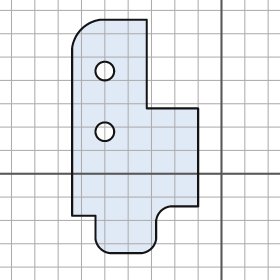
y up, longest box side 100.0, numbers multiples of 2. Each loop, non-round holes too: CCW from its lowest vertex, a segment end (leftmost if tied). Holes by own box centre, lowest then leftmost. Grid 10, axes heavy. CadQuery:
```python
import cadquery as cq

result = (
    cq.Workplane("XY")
    .moveTo(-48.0, -34.0)
    .lineTo(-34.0, -34.0)
    .threePointArc((-30.0, -32.0), (-28.0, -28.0))
    .lineTo(-28.0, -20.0)
    .threePointArc((-26.0, -16.0), (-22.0, -14.0))
    .lineTo(-10.0, -14.0)
    .lineTo(-10.0, 28.0)
    .lineTo(-32.0, 28.0)
    .lineTo(-32.0, 66.0)
    .lineTo(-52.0, 66.0)
    .threePointArc((-60.0, 62.0), (-64.0, 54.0))
    .lineTo(-64.0, -18.0)
    .lineTo(-54.0, -18.0)
    .lineTo(-54.0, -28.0)
    .threePointArc((-52.0, -32.0), (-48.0, -34.0))
    .close()
    .moveTo(-50.0, 18.0)
    .circle(4.0)
    .moveTo(-50.0, 44.0)
    .circle(4.0)
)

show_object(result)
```